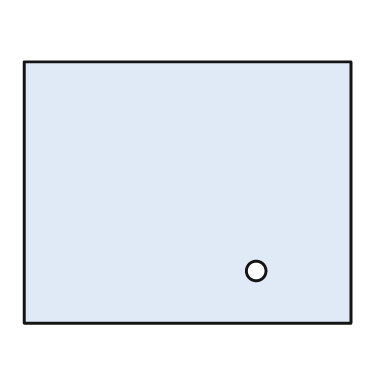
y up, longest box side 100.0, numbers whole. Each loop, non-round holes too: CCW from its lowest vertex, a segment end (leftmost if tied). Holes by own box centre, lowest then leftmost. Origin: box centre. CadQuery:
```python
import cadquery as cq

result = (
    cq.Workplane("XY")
    .moveTo(-50.0, -40.0)
    .lineTo(50.0, -40.0)
    .lineTo(50.0, 40.0)
    .lineTo(-50.0, 40.0)
    .close()
    .moveTo(21.0, -24.0)
    .circle(3.0)
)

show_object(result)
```